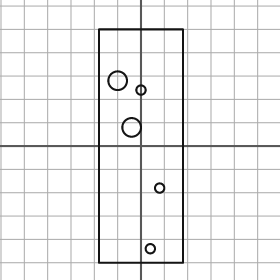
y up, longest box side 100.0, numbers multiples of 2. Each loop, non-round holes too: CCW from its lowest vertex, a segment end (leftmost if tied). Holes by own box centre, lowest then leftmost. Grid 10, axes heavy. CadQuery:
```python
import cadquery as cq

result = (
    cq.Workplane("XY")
    .moveTo(-18.0, -50.0)
    .lineTo(18.0, -50.0)
    .lineTo(18.0, 50.0)
    .lineTo(-18.0, 50.0)
    .close()
    .moveTo(4.0, -44.0)
    .circle(2.0)
    .moveTo(8.0, -18.0)
    .circle(2.0)
    .moveTo(-4.0, 8.0)
    .circle(4.0)
    .moveTo(0.0, 24.0)
    .circle(2.0)
    .moveTo(-10.0, 28.0)
    .circle(4.0)
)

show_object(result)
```